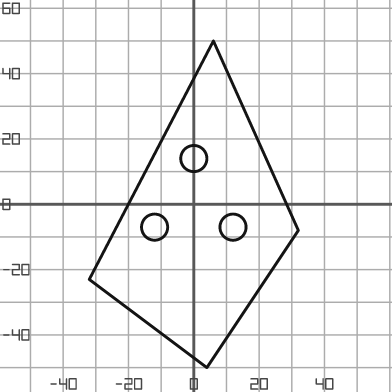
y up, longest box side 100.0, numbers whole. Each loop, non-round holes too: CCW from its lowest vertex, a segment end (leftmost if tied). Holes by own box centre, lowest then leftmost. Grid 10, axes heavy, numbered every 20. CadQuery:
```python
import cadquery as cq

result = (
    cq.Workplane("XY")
    .moveTo(4.0, -50.0)
    .lineTo(32.0, -8.0)
    .lineTo(6.0, 50.0)
    .lineTo(-32.0, -23.0)
    .close()
    .moveTo(-12.0, -7.0)
    .circle(4.0)
    .moveTo(12.0, -7.0)
    .circle(4.0)
    .moveTo(0.0, 14.0)
    .circle(4.0)
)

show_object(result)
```